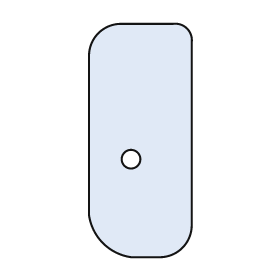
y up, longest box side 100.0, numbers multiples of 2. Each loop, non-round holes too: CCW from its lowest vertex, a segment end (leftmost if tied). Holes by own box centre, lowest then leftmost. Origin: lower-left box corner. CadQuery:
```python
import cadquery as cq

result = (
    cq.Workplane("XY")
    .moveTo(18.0, 0.0)
    .lineTo(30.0, 0.0)
    .threePointArc((40.0, 4.0), (44.0, 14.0))
    .lineTo(44.0, 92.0)
    .threePointArc((42.0, 98.0), (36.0, 100.0))
    .lineTo(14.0, 100.0)
    .threePointArc((4.0, 96.0), (0.0, 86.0))
    .lineTo(0.0, 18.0)
    .threePointArc((6.0, 6.0), (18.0, 0.0))
    .close()
    .moveTo(18.0, 42.0)
    .circle(4.0)
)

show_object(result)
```